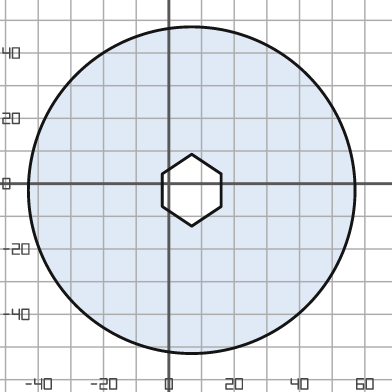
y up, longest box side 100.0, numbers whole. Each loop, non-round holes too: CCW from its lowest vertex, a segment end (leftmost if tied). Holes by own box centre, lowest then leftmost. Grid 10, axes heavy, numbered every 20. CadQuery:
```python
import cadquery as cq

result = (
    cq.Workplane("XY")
    .moveTo(7.0, -2.0)
    .circle(50.0)
    .moveTo(7.0, -13.0)
    .lineTo(16.0, -7.0)
    .lineTo(16.0, 3.0)
    .lineTo(7.0, 9.0)
    .lineTo(-2.0, 3.0)
    .lineTo(-2.0, -7.0)
    .close()
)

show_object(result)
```